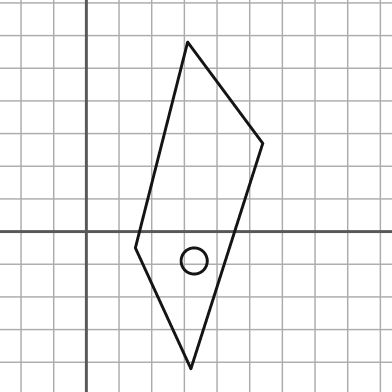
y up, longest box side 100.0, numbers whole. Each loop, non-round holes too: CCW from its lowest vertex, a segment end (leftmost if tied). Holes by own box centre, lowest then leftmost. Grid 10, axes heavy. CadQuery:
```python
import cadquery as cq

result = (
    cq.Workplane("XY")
    .moveTo(32.0, -42.0)
    .lineTo(54.0, 27.0)
    .lineTo(31.0, 58.0)
    .lineTo(15.0, -5.0)
    .close()
    .moveTo(33.0, -9.0)
    .circle(4.0)
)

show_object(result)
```